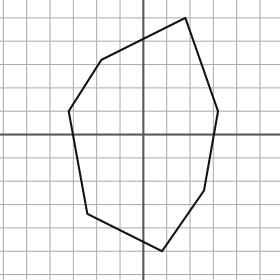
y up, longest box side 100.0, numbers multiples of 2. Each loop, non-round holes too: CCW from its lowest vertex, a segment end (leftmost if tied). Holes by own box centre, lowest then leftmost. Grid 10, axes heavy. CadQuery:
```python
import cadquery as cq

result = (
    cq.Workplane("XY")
    .moveTo(8.0, -50.0)
    .lineTo(26.0, -24.0)
    .lineTo(32.0, 10.0)
    .lineTo(18.0, 50.0)
    .lineTo(-18.0, 32.0)
    .lineTo(-32.0, 10.0)
    .lineTo(-24.0, -34.0)
    .close()
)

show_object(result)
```